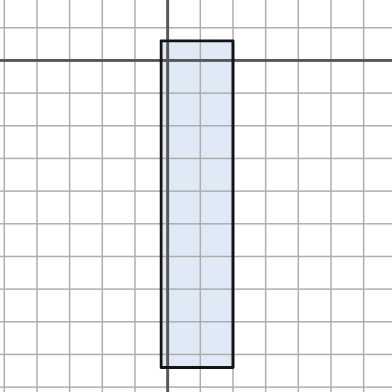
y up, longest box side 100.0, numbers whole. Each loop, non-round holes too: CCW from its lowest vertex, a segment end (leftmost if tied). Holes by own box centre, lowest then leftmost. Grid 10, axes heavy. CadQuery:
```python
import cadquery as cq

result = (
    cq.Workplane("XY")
    .moveTo(-2.0, -94.0)
    .lineTo(20.0, -94.0)
    .lineTo(20.0, 6.0)
    .lineTo(-2.0, 6.0)
    .close()
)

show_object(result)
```